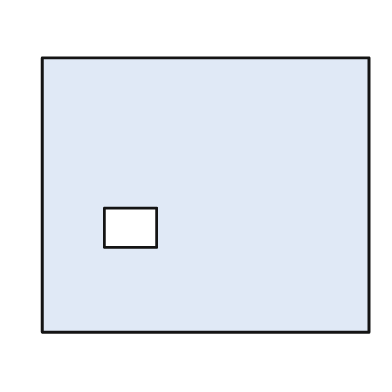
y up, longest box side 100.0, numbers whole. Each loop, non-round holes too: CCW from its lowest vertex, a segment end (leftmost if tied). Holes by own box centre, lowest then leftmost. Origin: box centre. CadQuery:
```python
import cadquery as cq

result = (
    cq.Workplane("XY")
    .moveTo(-50.0, -42.0)
    .lineTo(50.0, -42.0)
    .lineTo(50.0, 42.0)
    .lineTo(-50.0, 42.0)
    .close()
    .moveTo(-31.0, -16.0)
    .lineTo(-15.0, -16.0)
    .lineTo(-15.0, -4.0)
    .lineTo(-31.0, -4.0)
    .close()
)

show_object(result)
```